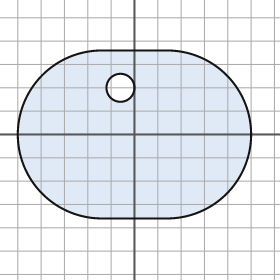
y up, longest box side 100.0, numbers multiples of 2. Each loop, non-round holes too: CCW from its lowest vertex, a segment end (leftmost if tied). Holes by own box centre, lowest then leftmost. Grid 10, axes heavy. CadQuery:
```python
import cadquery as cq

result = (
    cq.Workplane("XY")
    .moveTo(-14.0, -36.0)
    .lineTo(14.0, -36.0)
    .threePointArc((50.0, 0.0), (14.0, 36.0))
    .lineTo(-14.0, 36.0)
    .threePointArc((-50.0, 0.0), (-14.0, -36.0))
    .close()
    .moveTo(-6.0, 20.0)
    .circle(6.0)
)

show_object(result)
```